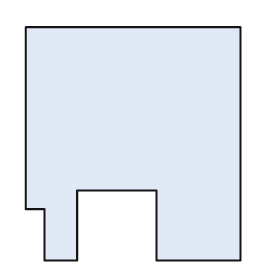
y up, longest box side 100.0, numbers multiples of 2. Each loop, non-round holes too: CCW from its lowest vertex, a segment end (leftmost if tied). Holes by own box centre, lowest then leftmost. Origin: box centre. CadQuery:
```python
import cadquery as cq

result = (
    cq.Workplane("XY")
    .moveTo(-38.0, -50.0)
    .lineTo(-24.0, -50.0)
    .lineTo(-24.0, -20.0)
    .lineTo(10.0, -20.0)
    .lineTo(10.0, -50.0)
    .lineTo(46.0, -50.0)
    .lineTo(46.0, 50.0)
    .lineTo(-46.0, 50.0)
    .lineTo(-46.0, -28.0)
    .lineTo(-38.0, -28.0)
    .close()
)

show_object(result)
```